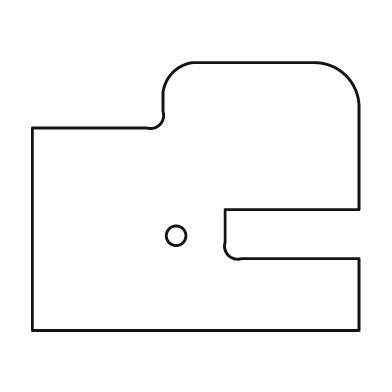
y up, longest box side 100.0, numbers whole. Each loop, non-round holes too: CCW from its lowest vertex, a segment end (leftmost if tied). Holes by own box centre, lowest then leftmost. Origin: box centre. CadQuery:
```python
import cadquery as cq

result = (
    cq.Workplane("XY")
    .moveTo(-50.0, -41.0)
    .lineTo(50.0, -41.0)
    .lineTo(50.0, -19.0)
    .lineTo(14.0, -19.0)
    .threePointArc((10.0, -18.0), (9.0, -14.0))
    .lineTo(9.0, -4.0)
    .lineTo(50.0, -4.0)
    .lineTo(50.0, 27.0)
    .threePointArc((46.0, 37.0), (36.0, 41.0))
    .lineTo(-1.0, 41.0)
    .threePointArc((-7.0, 38.0), (-10.0, 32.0))
    .lineTo(-10.0, 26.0)
    .threePointArc((-11.0, 22.0), (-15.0, 21.0))
    .lineTo(-50.0, 21.0)
    .close()
    .moveTo(-6.0, -12.0)
    .circle(3.0)
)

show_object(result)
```